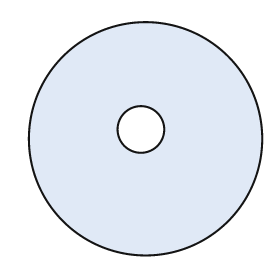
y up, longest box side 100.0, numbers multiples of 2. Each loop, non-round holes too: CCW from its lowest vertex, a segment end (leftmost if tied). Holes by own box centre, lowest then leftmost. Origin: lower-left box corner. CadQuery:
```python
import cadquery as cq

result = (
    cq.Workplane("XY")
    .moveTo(50.0, 50.0)
    .circle(50.0)
    .moveTo(48.0, 54.0)
    .circle(10.0)
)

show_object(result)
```